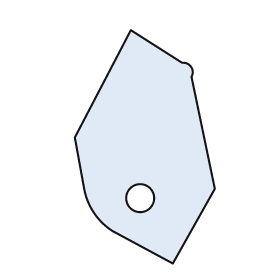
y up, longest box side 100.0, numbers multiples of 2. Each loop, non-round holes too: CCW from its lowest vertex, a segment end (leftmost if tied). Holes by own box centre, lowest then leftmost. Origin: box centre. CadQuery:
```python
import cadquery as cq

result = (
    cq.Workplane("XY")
    .moveTo(12.0, -50.0)
    .lineTo(30.0, -18.0)
    .lineTo(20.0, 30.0)
    .threePointArc((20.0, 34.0), (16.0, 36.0))
    .lineTo(-6.0, 50.0)
    .lineTo(-30.0, 4.0)
    .lineTo(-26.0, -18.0)
    .threePointArc((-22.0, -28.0), (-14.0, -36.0))
    .close()
    .moveTo(-2.0, -22.0)
    .circle(6.0)
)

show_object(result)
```